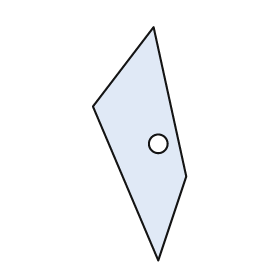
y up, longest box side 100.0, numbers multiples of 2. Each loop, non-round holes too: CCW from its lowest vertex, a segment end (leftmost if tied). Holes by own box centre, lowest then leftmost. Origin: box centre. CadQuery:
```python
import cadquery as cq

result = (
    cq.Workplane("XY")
    .moveTo(8.0, -50.0)
    .lineTo(20.0, -14.0)
    .lineTo(6.0, 50.0)
    .lineTo(-20.0, 16.0)
    .close()
    .moveTo(8.0, 0.0)
    .circle(4.0)
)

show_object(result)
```